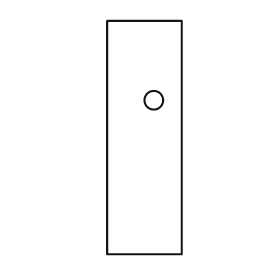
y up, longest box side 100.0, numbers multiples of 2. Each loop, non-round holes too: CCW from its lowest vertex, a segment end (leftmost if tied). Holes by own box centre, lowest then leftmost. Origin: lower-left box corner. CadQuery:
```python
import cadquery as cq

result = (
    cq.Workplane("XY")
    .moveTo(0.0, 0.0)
    .lineTo(32.0, 0.0)
    .lineTo(32.0, 100.0)
    .lineTo(0.0, 100.0)
    .close()
    .moveTo(20.0, 66.0)
    .circle(4.0)
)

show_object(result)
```